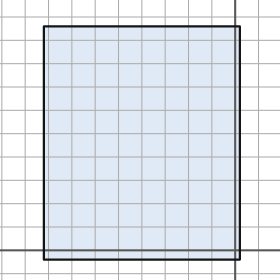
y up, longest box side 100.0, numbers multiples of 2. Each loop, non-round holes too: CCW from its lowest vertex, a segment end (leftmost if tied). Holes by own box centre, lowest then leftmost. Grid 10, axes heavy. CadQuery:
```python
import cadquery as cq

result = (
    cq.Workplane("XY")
    .moveTo(-82.0, -4.0)
    .lineTo(2.0, -4.0)
    .lineTo(2.0, 96.0)
    .lineTo(-82.0, 96.0)
    .close()
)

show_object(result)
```